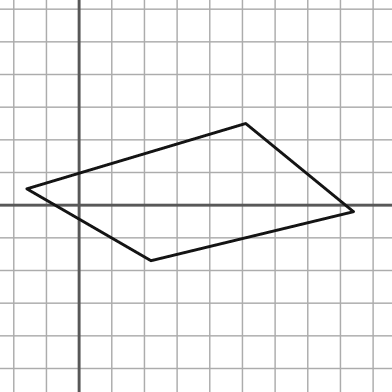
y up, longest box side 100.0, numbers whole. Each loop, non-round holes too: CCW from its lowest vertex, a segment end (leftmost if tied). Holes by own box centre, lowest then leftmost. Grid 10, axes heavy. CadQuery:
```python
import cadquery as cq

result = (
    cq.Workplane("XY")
    .moveTo(22.0, -17.0)
    .lineTo(84.0, -2.0)
    .lineTo(51.0, 25.0)
    .lineTo(-16.0, 5.0)
    .close()
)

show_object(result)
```